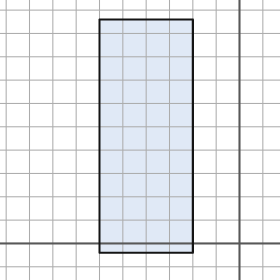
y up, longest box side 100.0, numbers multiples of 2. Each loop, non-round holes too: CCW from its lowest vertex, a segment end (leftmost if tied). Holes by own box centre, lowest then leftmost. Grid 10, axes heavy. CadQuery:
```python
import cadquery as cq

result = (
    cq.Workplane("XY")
    .moveTo(-60.0, -4.0)
    .lineTo(-20.0, -4.0)
    .lineTo(-20.0, 96.0)
    .lineTo(-60.0, 96.0)
    .close()
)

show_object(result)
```